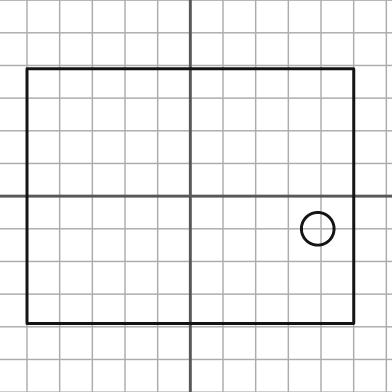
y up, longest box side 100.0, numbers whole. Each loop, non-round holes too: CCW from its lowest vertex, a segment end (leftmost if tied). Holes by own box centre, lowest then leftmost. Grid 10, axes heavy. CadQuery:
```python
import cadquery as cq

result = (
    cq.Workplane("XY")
    .moveTo(-50.0, -39.0)
    .lineTo(50.0, -39.0)
    .lineTo(50.0, 39.0)
    .lineTo(-50.0, 39.0)
    .close()
    .moveTo(39.0, -10.0)
    .circle(5.0)
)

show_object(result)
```